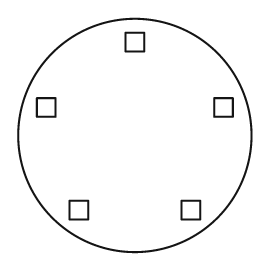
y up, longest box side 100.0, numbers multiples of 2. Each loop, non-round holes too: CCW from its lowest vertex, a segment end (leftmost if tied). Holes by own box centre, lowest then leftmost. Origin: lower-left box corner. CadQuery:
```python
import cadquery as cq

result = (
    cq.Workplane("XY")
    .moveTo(50.0, 50.0)
    .circle(50.0)
    .moveTo(22.0, 14.0)
    .lineTo(30.0, 14.0)
    .lineTo(30.0, 22.0)
    .lineTo(22.0, 22.0)
    .close()
    .moveTo(70.0, 14.0)
    .lineTo(78.0, 14.0)
    .lineTo(78.0, 22.0)
    .lineTo(70.0, 22.0)
    .close()
    .moveTo(8.0, 58.0)
    .lineTo(16.0, 58.0)
    .lineTo(16.0, 66.0)
    .lineTo(8.0, 66.0)
    .close()
    .moveTo(84.0, 58.0)
    .lineTo(92.0, 58.0)
    .lineTo(92.0, 66.0)
    .lineTo(84.0, 66.0)
    .close()
    .moveTo(46.0, 86.0)
    .lineTo(54.0, 86.0)
    .lineTo(54.0, 94.0)
    .lineTo(46.0, 94.0)
    .close()
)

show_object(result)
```